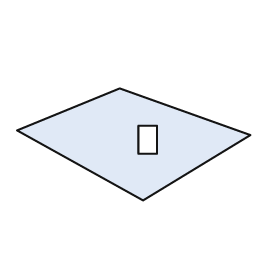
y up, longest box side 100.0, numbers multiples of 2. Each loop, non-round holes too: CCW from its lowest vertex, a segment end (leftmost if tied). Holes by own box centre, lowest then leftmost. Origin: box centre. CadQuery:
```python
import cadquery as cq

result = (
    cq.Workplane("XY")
    .moveTo(4.0, -24.0)
    .lineTo(50.0, 4.0)
    .lineTo(-6.0, 24.0)
    .lineTo(-50.0, 6.0)
    .close()
    .moveTo(2.0, -4.0)
    .lineTo(10.0, -4.0)
    .lineTo(10.0, 8.0)
    .lineTo(2.0, 8.0)
    .close()
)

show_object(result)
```